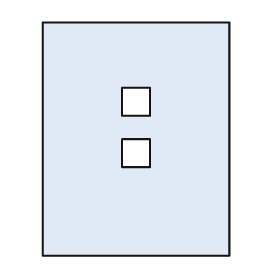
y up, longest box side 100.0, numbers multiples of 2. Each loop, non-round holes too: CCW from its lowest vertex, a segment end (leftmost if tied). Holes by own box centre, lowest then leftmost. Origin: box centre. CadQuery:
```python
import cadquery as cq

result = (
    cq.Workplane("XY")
    .moveTo(-40.0, -50.0)
    .lineTo(40.0, -50.0)
    .lineTo(40.0, 50.0)
    .lineTo(-40.0, 50.0)
    .close()
    .moveTo(-6.0, -12.0)
    .lineTo(6.0, -12.0)
    .lineTo(6.0, 0.0)
    .lineTo(-6.0, 0.0)
    .close()
    .moveTo(-6.0, 10.0)
    .lineTo(6.0, 10.0)
    .lineTo(6.0, 22.0)
    .lineTo(-6.0, 22.0)
    .close()
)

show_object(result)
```